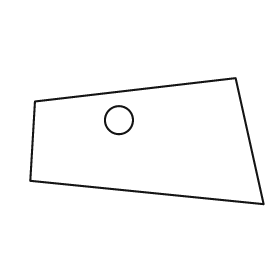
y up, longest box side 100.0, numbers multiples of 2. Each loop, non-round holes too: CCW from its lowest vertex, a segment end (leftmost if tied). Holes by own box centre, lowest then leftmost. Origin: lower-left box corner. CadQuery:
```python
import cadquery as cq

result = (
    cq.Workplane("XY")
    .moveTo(100.0, 0.0)
    .lineTo(88.0, 54.0)
    .lineTo(2.0, 44.0)
    .lineTo(0.0, 10.0)
    .close()
    .moveTo(38.0, 36.0)
    .circle(6.0)
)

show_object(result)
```